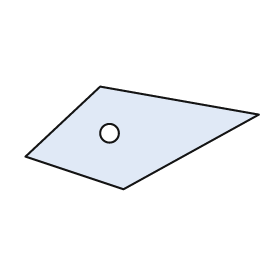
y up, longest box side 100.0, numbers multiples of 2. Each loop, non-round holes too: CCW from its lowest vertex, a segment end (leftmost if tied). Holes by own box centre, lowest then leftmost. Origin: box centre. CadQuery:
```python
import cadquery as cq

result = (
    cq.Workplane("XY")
    .moveTo(-8.0, -22.0)
    .lineTo(50.0, 10.0)
    .lineTo(-18.0, 22.0)
    .lineTo(-50.0, -8.0)
    .close()
    .moveTo(-14.0, 2.0)
    .circle(4.0)
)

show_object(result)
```